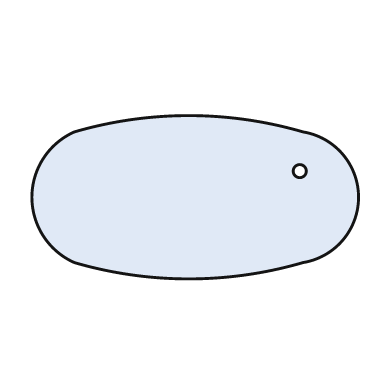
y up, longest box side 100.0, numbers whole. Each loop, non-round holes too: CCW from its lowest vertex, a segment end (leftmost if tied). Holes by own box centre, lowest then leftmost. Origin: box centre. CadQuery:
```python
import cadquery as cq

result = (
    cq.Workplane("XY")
    .moveTo(-37.0, -20.0)
    .threePointArc((-2.0, -25.0), (33.0, -20.0))
    .threePointArc((50.0, 0.0), (33.0, 20.0))
    .threePointArc((-2.0, 25.0), (-37.0, 20.0))
    .threePointArc((-50.0, 0.0), (-37.0, -20.0))
    .close()
    .moveTo(32.0, 8.0)
    .circle(2.0)
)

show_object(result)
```